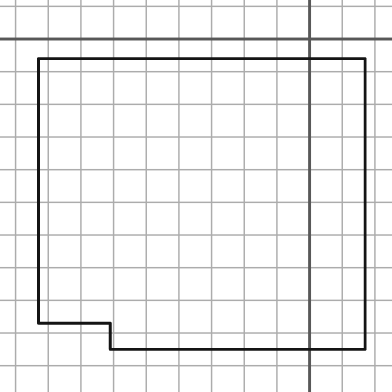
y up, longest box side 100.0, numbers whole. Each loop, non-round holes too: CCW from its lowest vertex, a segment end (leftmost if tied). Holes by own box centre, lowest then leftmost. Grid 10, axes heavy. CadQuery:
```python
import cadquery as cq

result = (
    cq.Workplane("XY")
    .moveTo(-61.0, -95.0)
    .lineTo(17.0, -95.0)
    .lineTo(17.0, -6.0)
    .lineTo(-83.0, -6.0)
    .lineTo(-83.0, -87.0)
    .lineTo(-61.0, -87.0)
    .close()
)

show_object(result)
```